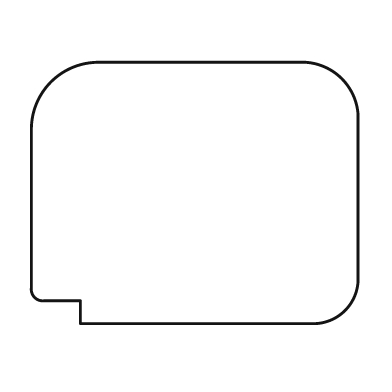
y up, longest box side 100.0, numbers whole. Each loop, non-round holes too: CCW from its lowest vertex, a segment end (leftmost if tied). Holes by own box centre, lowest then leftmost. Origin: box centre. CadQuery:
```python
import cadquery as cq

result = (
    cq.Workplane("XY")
    .moveTo(-35.0, -40.0)
    .lineTo(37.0, -40.0)
    .threePointArc((46.0, -36.0), (50.0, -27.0))
    .lineTo(50.0, 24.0)
    .threePointArc((45.0, 35.0), (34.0, 40.0))
    .lineTo(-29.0, 40.0)
    .threePointArc((-44.0, 34.0), (-50.0, 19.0))
    .lineTo(-50.0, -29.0)
    .threePointArc((-49.0, -32.0), (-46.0, -33.0))
    .lineTo(-35.0, -33.0)
    .close()
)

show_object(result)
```